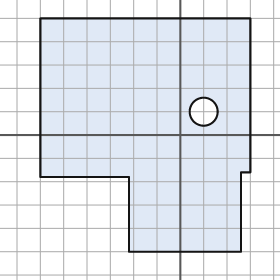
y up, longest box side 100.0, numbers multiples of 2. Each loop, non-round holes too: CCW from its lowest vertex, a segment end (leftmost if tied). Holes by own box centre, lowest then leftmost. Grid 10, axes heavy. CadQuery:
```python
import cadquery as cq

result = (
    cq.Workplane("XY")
    .moveTo(-22.0, -50.0)
    .lineTo(26.0, -50.0)
    .lineTo(26.0, -16.0)
    .lineTo(30.0, -16.0)
    .lineTo(30.0, 50.0)
    .lineTo(-60.0, 50.0)
    .lineTo(-60.0, -18.0)
    .lineTo(-22.0, -18.0)
    .close()
    .moveTo(10.0, 10.0)
    .circle(6.0)
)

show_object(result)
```